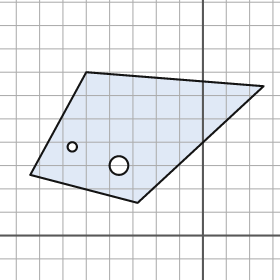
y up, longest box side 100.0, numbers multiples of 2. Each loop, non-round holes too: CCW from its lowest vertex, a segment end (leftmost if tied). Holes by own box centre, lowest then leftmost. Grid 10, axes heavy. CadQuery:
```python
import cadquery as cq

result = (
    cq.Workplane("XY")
    .moveTo(-28.0, 14.0)
    .lineTo(26.0, 64.0)
    .lineTo(-50.0, 70.0)
    .lineTo(-74.0, 26.0)
    .close()
    .moveTo(-36.0, 30.0)
    .circle(4.0)
    .moveTo(-56.0, 38.0)
    .circle(2.0)
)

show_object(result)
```